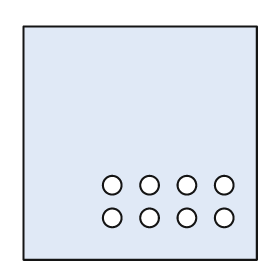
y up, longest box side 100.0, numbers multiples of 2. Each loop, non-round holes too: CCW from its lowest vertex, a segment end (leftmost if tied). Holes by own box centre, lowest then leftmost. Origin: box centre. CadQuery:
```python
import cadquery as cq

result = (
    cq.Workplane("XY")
    .moveTo(-50.0, -50.0)
    .lineTo(50.0, -50.0)
    .lineTo(50.0, 50.0)
    .lineTo(-50.0, 50.0)
    .close()
    .moveTo(-12.0, -32.0)
    .circle(4.0)
    .moveTo(4.0, -32.0)
    .circle(4.0)
    .moveTo(20.0, -32.0)
    .circle(4.0)
    .moveTo(36.0, -32.0)
    .circle(4.0)
    .moveTo(-12.0, -18.0)
    .circle(4.0)
    .moveTo(4.0, -18.0)
    .circle(4.0)
    .moveTo(20.0, -18.0)
    .circle(4.0)
    .moveTo(36.0, -18.0)
    .circle(4.0)
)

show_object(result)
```